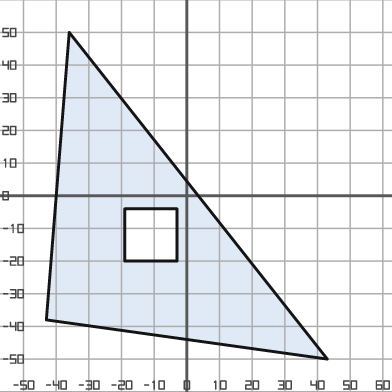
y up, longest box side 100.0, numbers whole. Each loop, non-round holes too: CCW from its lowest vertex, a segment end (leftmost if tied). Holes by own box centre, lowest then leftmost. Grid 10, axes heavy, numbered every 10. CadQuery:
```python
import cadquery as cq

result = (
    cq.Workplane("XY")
    .moveTo(43.0, -50.0)
    .lineTo(-36.0, 50.0)
    .lineTo(-43.0, -38.0)
    .close()
    .moveTo(-19.0, -20.0)
    .lineTo(-3.0, -20.0)
    .lineTo(-3.0, -4.0)
    .lineTo(-19.0, -4.0)
    .close()
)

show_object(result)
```